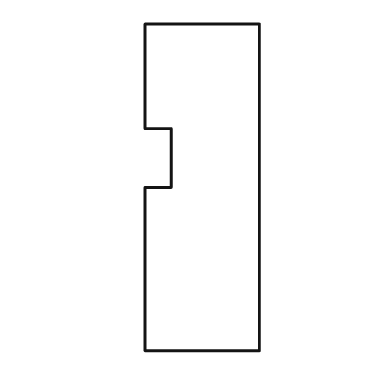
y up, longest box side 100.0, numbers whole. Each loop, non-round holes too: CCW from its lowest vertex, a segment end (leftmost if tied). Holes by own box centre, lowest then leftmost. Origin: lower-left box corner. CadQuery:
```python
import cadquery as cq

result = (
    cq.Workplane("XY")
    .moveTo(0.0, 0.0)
    .lineTo(35.0, 0.0)
    .lineTo(35.0, 100.0)
    .lineTo(0.0, 100.0)
    .lineTo(0.0, 68.0)
    .lineTo(8.0, 68.0)
    .lineTo(8.0, 50.0)
    .lineTo(0.0, 50.0)
    .close()
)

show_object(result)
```